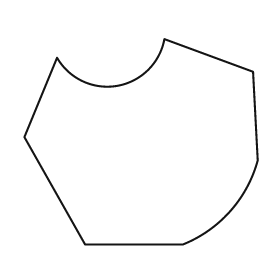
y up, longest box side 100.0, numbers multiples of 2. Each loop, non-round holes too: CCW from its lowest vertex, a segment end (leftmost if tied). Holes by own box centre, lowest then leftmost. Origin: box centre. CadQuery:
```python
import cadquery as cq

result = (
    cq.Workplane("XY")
    .moveTo(-24.0, -44.0)
    .lineTo(18.0, -44.0)
    .threePointArc((38.0, -30.0), (50.0, -8.0))
    .lineTo(48.0, 30.0)
    .lineTo(10.0, 44.0)
    .threePointArc((-10.0, 24.0), (-36.0, 36.0))
    .lineTo(-50.0, 2.0)
    .close()
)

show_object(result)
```